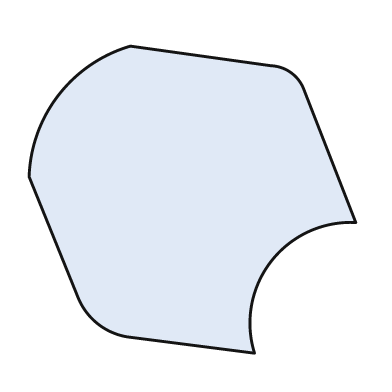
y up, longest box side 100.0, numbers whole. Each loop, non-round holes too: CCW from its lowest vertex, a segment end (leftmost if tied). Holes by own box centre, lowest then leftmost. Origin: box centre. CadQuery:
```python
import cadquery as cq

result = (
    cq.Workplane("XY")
    .moveTo(19.0, -47.0)
    .threePointArc((24.0, -19.0), (50.0, -7.0))
    .lineTo(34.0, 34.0)
    .threePointArc((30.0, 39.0), (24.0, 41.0))
    .lineTo(-19.0, 47.0)
    .threePointArc((-41.0, 32.0), (-50.0, 7.0))
    .lineTo(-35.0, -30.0)
    .threePointArc((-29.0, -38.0), (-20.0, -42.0))
    .close()
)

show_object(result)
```